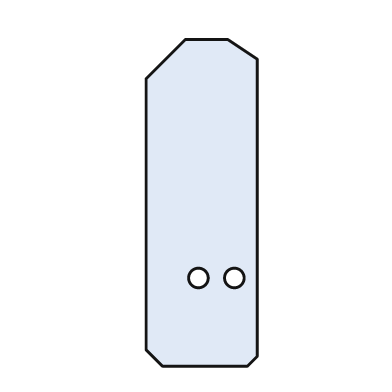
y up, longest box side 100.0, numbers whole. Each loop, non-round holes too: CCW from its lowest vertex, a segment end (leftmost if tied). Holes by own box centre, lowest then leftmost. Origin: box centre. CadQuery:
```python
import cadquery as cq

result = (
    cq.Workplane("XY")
    .moveTo(-12.0, -50.0)
    .lineTo(14.0, -50.0)
    .lineTo(17.0, -47.0)
    .lineTo(17.0, 44.0)
    .lineTo(8.0, 50.0)
    .lineTo(-5.0, 50.0)
    .lineTo(-17.0, 38.0)
    .lineTo(-17.0, -45.0)
    .close()
    .moveTo(-1.0, -23.0)
    .circle(3.0)
    .moveTo(10.0, -23.0)
    .circle(3.0)
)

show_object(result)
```